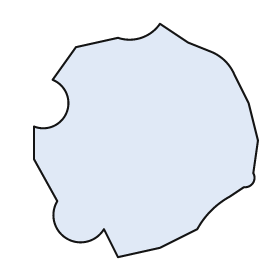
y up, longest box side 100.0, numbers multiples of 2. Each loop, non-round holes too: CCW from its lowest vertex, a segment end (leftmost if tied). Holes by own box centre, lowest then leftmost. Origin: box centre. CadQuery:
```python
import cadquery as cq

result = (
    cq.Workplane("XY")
    .moveTo(-12.0, -50.0)
    .lineTo(6.0, -46.0)
    .lineTo(22.0, -38.0)
    .threePointArc((28.0, -30.0), (36.0, -24.0))
    .lineTo(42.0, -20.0)
    .threePointArc((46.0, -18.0), (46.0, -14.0))
    .lineTo(48.0, 0.0)
    .lineTo(44.0, 16.0)
    .lineTo(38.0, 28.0)
    .threePointArc((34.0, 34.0), (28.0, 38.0))
    .lineTo(18.0, 42.0)
    .lineTo(6.0, 50.0)
    .threePointArc((-2.0, 44.0), (-12.0, 44.0))
    .lineTo(-30.0, 40.0)
    .lineTo(-40.0, 26.0)
    .threePointArc((-34.0, 12.0), (-48.0, 6.0))
    .lineTo(-48.0, -8.0)
    .lineTo(-38.0, -26.0)
    .threePointArc((-34.0, -42.0), (-18.0, -38.0))
    .close()
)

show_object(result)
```